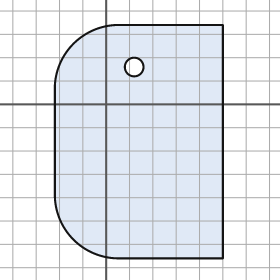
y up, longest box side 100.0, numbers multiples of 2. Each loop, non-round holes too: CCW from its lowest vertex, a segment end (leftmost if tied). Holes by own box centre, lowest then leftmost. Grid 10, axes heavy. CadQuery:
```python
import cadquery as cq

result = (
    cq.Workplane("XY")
    .moveTo(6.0, -66.0)
    .lineTo(50.0, -66.0)
    .lineTo(50.0, 34.0)
    .lineTo(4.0, 34.0)
    .threePointArc((-14.0, 26.0), (-22.0, 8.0))
    .lineTo(-22.0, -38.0)
    .threePointArc((-14.0, -58.0), (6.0, -66.0))
    .close()
    .moveTo(12.0, 16.0)
    .circle(4.0)
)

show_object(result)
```